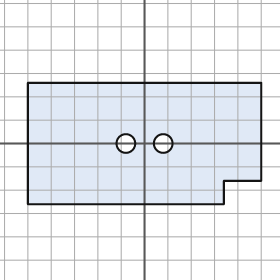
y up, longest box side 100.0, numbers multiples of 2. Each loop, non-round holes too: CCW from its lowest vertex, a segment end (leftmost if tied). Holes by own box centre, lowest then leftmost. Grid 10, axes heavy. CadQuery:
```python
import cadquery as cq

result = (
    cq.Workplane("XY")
    .moveTo(-50.0, -26.0)
    .lineTo(34.0, -26.0)
    .lineTo(34.0, -16.0)
    .lineTo(50.0, -16.0)
    .lineTo(50.0, 26.0)
    .lineTo(-50.0, 26.0)
    .close()
    .moveTo(-8.0, 0.0)
    .circle(4.0)
    .moveTo(8.0, 0.0)
    .circle(4.0)
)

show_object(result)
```